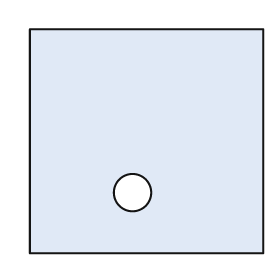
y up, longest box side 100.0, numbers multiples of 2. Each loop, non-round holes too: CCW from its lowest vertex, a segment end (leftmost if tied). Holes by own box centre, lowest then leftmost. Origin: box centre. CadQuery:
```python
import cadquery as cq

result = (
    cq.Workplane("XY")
    .moveTo(-50.0, -48.0)
    .lineTo(50.0, -48.0)
    .lineTo(50.0, 48.0)
    .lineTo(-50.0, 48.0)
    .close()
    .moveTo(-6.0, -22.0)
    .circle(8.0)
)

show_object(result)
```